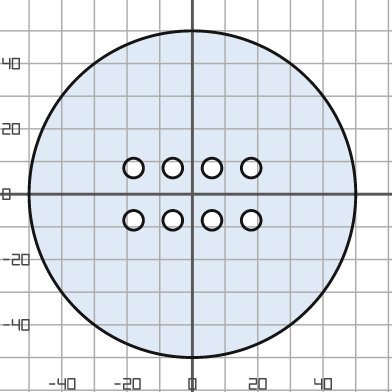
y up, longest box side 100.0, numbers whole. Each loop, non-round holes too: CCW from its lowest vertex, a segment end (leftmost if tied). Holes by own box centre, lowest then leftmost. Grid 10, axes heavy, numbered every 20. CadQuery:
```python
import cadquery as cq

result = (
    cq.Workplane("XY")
    .moveTo(0.0, 0.0)
    .circle(50.0)
    .moveTo(-18.0, -8.0)
    .circle(3.0)
    .moveTo(-6.0, -8.0)
    .circle(3.0)
    .moveTo(6.0, -8.0)
    .circle(3.0)
    .moveTo(18.0, -8.0)
    .circle(3.0)
    .moveTo(-18.0, 8.0)
    .circle(3.0)
    .moveTo(-6.0, 8.0)
    .circle(3.0)
    .moveTo(6.0, 8.0)
    .circle(3.0)
    .moveTo(18.0, 8.0)
    .circle(3.0)
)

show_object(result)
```